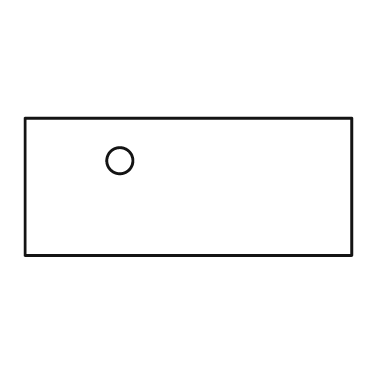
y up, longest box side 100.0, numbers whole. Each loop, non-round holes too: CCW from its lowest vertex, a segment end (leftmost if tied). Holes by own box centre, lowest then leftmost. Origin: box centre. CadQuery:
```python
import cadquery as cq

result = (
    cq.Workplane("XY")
    .moveTo(-50.0, -21.0)
    .lineTo(50.0, -21.0)
    .lineTo(50.0, 21.0)
    .lineTo(-50.0, 21.0)
    .close()
    .moveTo(-21.0, 8.0)
    .circle(4.0)
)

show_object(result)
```